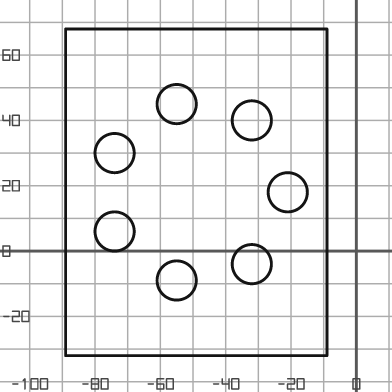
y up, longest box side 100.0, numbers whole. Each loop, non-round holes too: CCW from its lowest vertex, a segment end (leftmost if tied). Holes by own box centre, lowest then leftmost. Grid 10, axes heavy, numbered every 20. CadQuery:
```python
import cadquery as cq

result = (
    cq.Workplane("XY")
    .moveTo(-89.0, -32.0)
    .lineTo(-9.0, -32.0)
    .lineTo(-9.0, 68.0)
    .lineTo(-89.0, 68.0)
    .close()
    .moveTo(-55.0, -9.0)
    .circle(6.0)
    .moveTo(-32.0, -4.0)
    .circle(6.0)
    .moveTo(-74.0, 6.0)
    .circle(6.0)
    .moveTo(-21.0, 18.0)
    .circle(6.0)
    .moveTo(-74.0, 30.0)
    .circle(6.0)
    .moveTo(-32.0, 40.0)
    .circle(6.0)
    .moveTo(-55.0, 45.0)
    .circle(6.0)
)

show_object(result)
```